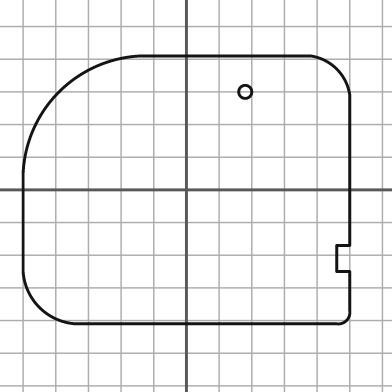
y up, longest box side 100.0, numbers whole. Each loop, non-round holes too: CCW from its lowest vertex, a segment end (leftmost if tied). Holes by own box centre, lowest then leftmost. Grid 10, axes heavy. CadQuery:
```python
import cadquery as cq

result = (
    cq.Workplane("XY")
    .moveTo(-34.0, -41.0)
    .lineTo(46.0, -41.0)
    .threePointArc((49.0, -40.0), (50.0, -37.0))
    .lineTo(50.0, -25.0)
    .lineTo(46.0, -25.0)
    .lineTo(46.0, -17.0)
    .lineTo(50.0, -17.0)
    .lineTo(50.0, 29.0)
    .threePointArc((46.0, 37.0), (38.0, 41.0))
    .lineTo(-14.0, 41.0)
    .threePointArc((-39.0, 30.0), (-50.0, 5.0))
    .lineTo(-50.0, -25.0)
    .threePointArc((-45.0, -36.0), (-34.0, -41.0))
    .close()
    .moveTo(18.0, 30.0)
    .circle(2.0)
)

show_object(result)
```